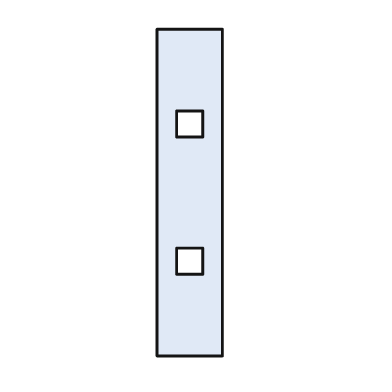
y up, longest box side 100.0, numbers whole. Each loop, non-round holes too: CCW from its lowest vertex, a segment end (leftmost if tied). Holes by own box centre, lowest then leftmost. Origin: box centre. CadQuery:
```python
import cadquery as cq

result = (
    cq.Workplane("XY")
    .moveTo(-10.0, -50.0)
    .lineTo(10.0, -50.0)
    .lineTo(10.0, 50.0)
    .lineTo(-10.0, 50.0)
    .close()
    .moveTo(-4.0, -25.0)
    .lineTo(4.0, -25.0)
    .lineTo(4.0, -17.0)
    .lineTo(-4.0, -17.0)
    .close()
    .moveTo(-4.0, 17.0)
    .lineTo(4.0, 17.0)
    .lineTo(4.0, 25.0)
    .lineTo(-4.0, 25.0)
    .close()
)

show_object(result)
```